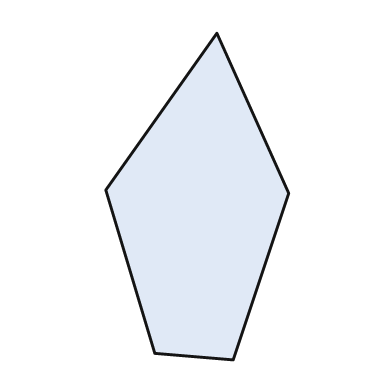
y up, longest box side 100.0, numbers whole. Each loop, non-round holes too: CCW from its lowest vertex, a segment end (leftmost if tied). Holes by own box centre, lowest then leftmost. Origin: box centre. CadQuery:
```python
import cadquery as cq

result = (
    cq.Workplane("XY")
    .moveTo(11.0, -50.0)
    .lineTo(28.0, 1.0)
    .lineTo(6.0, 50.0)
    .lineTo(-28.0, 2.0)
    .lineTo(-13.0, -48.0)
    .close()
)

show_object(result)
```